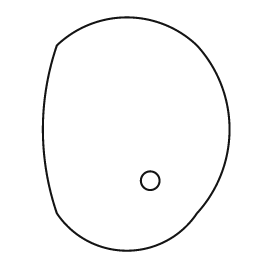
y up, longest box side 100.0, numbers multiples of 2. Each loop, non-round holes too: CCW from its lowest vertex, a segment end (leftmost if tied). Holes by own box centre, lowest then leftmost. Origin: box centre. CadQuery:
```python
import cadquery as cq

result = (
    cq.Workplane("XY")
    .moveTo(-34.0, -34.0)
    .threePointArc((-4.0, -50.0), (26.0, -34.0))
    .threePointArc((40.0, 2.0), (26.0, 38.0))
    .threePointArc((-4.0, 50.0), (-34.0, 38.0))
    .threePointArc((-40.0, 2.0), (-34.0, -34.0))
    .close()
    .moveTo(6.0, -20.0)
    .circle(4.0)
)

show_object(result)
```